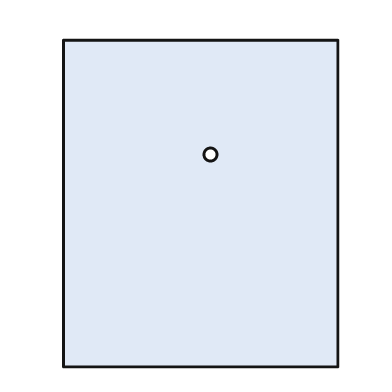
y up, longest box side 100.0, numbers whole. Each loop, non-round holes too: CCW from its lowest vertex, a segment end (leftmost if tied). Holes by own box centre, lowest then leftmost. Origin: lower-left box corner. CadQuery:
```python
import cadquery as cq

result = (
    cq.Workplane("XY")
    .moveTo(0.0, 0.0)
    .lineTo(84.0, 0.0)
    .lineTo(84.0, 100.0)
    .lineTo(0.0, 100.0)
    .close()
    .moveTo(45.0, 65.0)
    .circle(2.0)
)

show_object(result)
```